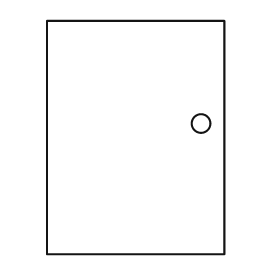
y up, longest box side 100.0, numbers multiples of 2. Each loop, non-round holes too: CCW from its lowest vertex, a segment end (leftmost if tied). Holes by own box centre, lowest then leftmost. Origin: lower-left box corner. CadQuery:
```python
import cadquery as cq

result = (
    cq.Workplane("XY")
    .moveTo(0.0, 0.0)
    .lineTo(76.0, 0.0)
    .lineTo(76.0, 100.0)
    .lineTo(0.0, 100.0)
    .close()
    .moveTo(66.0, 56.0)
    .circle(4.0)
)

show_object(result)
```